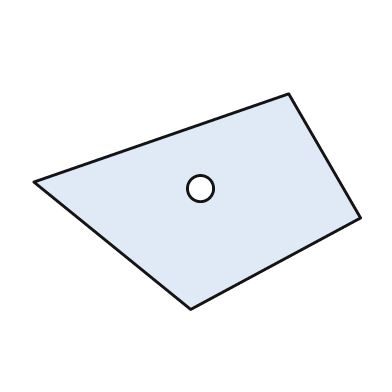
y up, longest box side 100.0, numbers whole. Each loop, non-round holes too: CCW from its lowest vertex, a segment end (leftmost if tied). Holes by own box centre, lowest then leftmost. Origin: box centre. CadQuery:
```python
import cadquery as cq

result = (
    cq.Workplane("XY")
    .moveTo(-2.0, -33.0)
    .lineTo(50.0, -5.0)
    .lineTo(28.0, 33.0)
    .lineTo(-50.0, 6.0)
    .close()
    .moveTo(1.0, 4.0)
    .circle(4.0)
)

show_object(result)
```